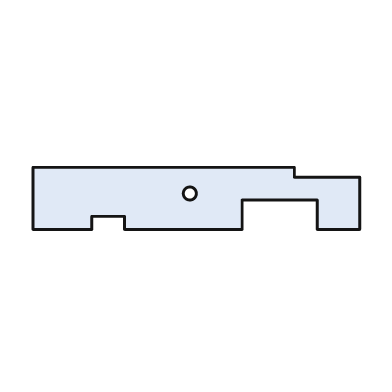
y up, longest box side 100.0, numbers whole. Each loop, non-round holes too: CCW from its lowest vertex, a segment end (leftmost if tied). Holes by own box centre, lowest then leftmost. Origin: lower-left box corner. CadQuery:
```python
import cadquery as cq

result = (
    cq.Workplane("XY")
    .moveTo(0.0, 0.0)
    .lineTo(18.0, 0.0)
    .lineTo(18.0, 4.0)
    .lineTo(28.0, 4.0)
    .lineTo(28.0, 0.0)
    .lineTo(64.0, 0.0)
    .lineTo(64.0, 9.0)
    .lineTo(87.0, 9.0)
    .lineTo(87.0, 0.0)
    .lineTo(100.0, 0.0)
    .lineTo(100.0, 16.0)
    .lineTo(80.0, 16.0)
    .lineTo(80.0, 19.0)
    .lineTo(0.0, 19.0)
    .close()
    .moveTo(48.0, 11.0)
    .circle(2.0)
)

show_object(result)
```